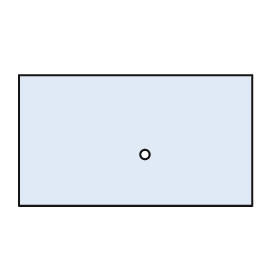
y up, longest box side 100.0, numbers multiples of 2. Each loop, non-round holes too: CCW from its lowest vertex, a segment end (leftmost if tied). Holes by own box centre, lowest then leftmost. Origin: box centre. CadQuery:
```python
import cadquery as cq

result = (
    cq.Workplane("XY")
    .moveTo(-50.0, -28.0)
    .lineTo(50.0, -28.0)
    .lineTo(50.0, 28.0)
    .lineTo(-50.0, 28.0)
    .close()
    .moveTo(4.0, -6.0)
    .circle(2.0)
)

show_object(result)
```